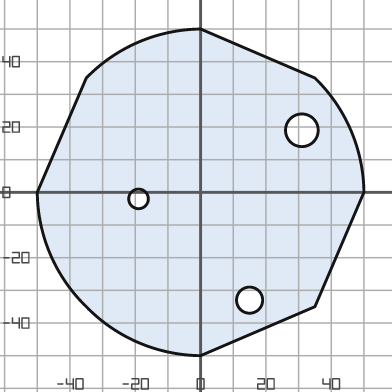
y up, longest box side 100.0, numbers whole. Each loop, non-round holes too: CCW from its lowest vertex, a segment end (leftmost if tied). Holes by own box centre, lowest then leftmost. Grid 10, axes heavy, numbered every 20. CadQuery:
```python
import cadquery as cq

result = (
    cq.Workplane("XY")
    .moveTo(0.0, -50.0)
    .lineTo(35.0, -35.0)
    .lineTo(50.0, 0.0)
    .threePointArc((46.0, 19.0), (35.0, 35.0))
    .lineTo(0.0, 50.0)
    .threePointArc((-19.0, 46.0), (-35.0, 35.0))
    .lineTo(-50.0, 0.0)
    .threePointArc((-46.0, -19.0), (-35.0, -35.0))
    .threePointArc((-19.0, -46.0), (0.0, -50.0))
    .close()
    .moveTo(15.0, -33.0)
    .circle(4.0)
    .moveTo(-19.0, -2.0)
    .circle(3.0)
    .moveTo(31.0, 19.0)
    .circle(5.0)
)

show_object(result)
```